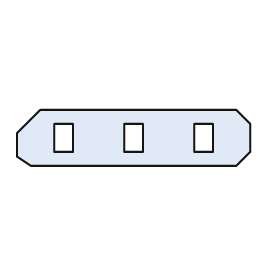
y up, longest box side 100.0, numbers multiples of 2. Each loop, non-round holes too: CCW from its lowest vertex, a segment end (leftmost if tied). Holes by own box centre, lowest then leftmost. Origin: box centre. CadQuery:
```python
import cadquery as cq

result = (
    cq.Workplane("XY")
    .moveTo(-44.0, -12.0)
    .lineTo(44.0, -12.0)
    .lineTo(50.0, -6.0)
    .lineTo(50.0, 6.0)
    .lineTo(44.0, 12.0)
    .lineTo(-40.0, 12.0)
    .lineTo(-50.0, 2.0)
    .lineTo(-50.0, -8.0)
    .close()
    .moveTo(-34.0, -6.0)
    .lineTo(-26.0, -6.0)
    .lineTo(-26.0, 6.0)
    .lineTo(-34.0, 6.0)
    .close()
    .moveTo(-4.0, -6.0)
    .lineTo(4.0, -6.0)
    .lineTo(4.0, 6.0)
    .lineTo(-4.0, 6.0)
    .close()
    .moveTo(26.0, -6.0)
    .lineTo(34.0, -6.0)
    .lineTo(34.0, 6.0)
    .lineTo(26.0, 6.0)
    .close()
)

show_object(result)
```